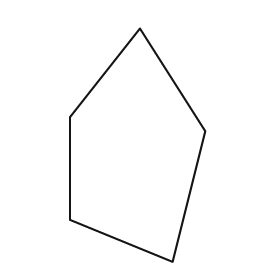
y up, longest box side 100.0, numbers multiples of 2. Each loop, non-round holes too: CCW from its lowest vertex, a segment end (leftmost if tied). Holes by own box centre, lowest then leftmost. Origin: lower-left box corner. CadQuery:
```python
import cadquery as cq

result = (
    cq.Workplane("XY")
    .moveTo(44.0, 0.0)
    .lineTo(58.0, 56.0)
    .lineTo(30.0, 100.0)
    .lineTo(0.0, 62.0)
    .lineTo(0.0, 18.0)
    .close()
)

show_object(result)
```